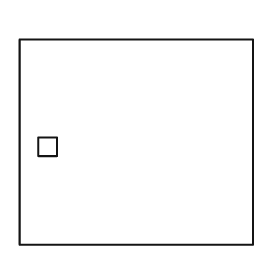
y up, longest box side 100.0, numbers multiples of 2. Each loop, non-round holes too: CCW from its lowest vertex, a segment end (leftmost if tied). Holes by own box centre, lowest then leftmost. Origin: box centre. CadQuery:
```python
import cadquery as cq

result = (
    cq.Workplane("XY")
    .moveTo(-50.0, -44.0)
    .lineTo(50.0, -44.0)
    .lineTo(50.0, 44.0)
    .lineTo(-50.0, 44.0)
    .close()
    .moveTo(-42.0, -6.0)
    .lineTo(-34.0, -6.0)
    .lineTo(-34.0, 2.0)
    .lineTo(-42.0, 2.0)
    .close()
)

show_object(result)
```